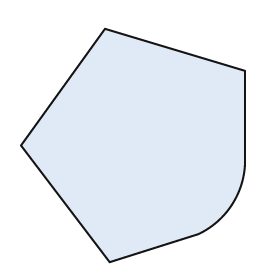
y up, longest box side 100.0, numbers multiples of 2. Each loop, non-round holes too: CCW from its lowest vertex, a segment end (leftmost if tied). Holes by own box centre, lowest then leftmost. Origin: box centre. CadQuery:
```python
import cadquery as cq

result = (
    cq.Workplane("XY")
    .moveTo(-10.0, -50.0)
    .lineTo(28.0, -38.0)
    .threePointArc((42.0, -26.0), (48.0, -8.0))
    .lineTo(48.0, 32.0)
    .lineTo(-12.0, 50.0)
    .lineTo(-48.0, 0.0)
    .close()
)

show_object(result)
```